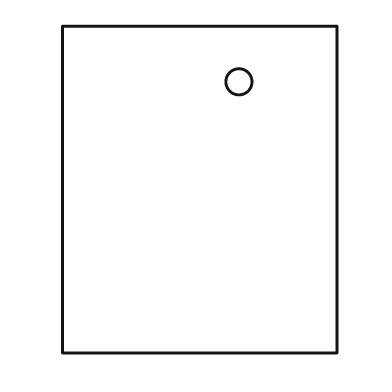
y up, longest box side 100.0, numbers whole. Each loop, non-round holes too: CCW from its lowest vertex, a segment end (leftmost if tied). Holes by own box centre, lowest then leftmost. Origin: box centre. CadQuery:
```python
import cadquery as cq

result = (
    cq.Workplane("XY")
    .moveTo(-42.0, -50.0)
    .lineTo(42.0, -50.0)
    .lineTo(42.0, 50.0)
    .lineTo(-42.0, 50.0)
    .close()
    .moveTo(12.0, 33.0)
    .circle(4.0)
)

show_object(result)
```